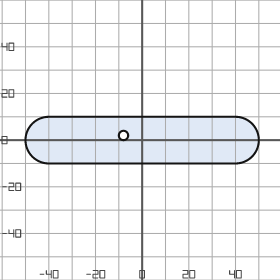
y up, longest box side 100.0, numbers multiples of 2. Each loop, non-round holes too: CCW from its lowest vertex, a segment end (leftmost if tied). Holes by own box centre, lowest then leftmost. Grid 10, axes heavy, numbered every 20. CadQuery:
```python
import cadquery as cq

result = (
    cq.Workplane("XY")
    .moveTo(-40.0, -10.0)
    .lineTo(40.0, -10.0)
    .threePointArc((50.0, 0.0), (40.0, 10.0))
    .lineTo(-40.0, 10.0)
    .threePointArc((-50.0, 0.0), (-40.0, -10.0))
    .close()
    .moveTo(-8.0, 2.0)
    .circle(2.0)
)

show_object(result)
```